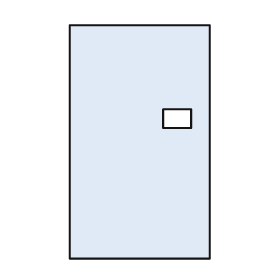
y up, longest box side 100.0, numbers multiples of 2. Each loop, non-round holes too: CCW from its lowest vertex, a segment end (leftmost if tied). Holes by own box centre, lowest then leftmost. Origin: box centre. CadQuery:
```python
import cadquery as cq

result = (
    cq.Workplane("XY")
    .moveTo(-30.0, -50.0)
    .lineTo(30.0, -50.0)
    .lineTo(30.0, 50.0)
    .lineTo(-30.0, 50.0)
    .close()
    .moveTo(10.0, 6.0)
    .lineTo(22.0, 6.0)
    .lineTo(22.0, 14.0)
    .lineTo(10.0, 14.0)
    .close()
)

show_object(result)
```